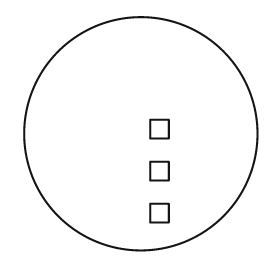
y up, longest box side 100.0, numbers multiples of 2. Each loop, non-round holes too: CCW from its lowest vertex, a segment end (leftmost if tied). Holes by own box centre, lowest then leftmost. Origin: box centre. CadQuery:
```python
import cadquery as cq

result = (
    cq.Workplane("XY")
    .moveTo(0.0, 0.0)
    .circle(50.0)
    .moveTo(4.0, -38.0)
    .lineTo(12.0, -38.0)
    .lineTo(12.0, -30.0)
    .lineTo(4.0, -30.0)
    .close()
    .moveTo(4.0, -20.0)
    .lineTo(12.0, -20.0)
    .lineTo(12.0, -12.0)
    .lineTo(4.0, -12.0)
    .close()
    .moveTo(4.0, -2.0)
    .lineTo(12.0, -2.0)
    .lineTo(12.0, 6.0)
    .lineTo(4.0, 6.0)
    .close()
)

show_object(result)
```